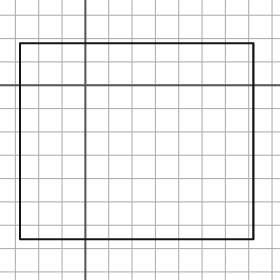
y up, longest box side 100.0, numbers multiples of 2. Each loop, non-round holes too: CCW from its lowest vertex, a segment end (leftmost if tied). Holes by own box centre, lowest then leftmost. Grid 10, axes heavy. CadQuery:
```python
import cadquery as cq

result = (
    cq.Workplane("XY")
    .moveTo(-28.0, -66.0)
    .lineTo(72.0, -66.0)
    .lineTo(72.0, 18.0)
    .lineTo(-28.0, 18.0)
    .close()
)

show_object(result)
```